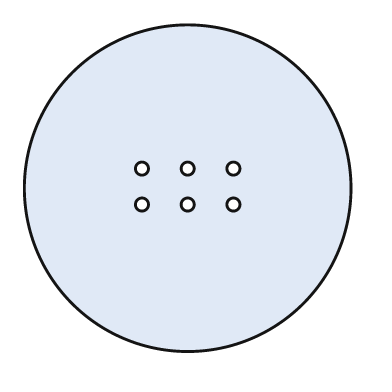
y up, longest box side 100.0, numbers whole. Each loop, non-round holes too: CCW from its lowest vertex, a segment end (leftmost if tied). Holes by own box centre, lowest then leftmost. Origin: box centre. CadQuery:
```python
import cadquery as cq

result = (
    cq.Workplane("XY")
    .moveTo(0.0, 0.0)
    .circle(50.0)
    .moveTo(-14.0, -5.0)
    .circle(2.0)
    .moveTo(0.0, -5.0)
    .circle(2.0)
    .moveTo(14.0, -5.0)
    .circle(2.0)
    .moveTo(-14.0, 6.0)
    .circle(2.0)
    .moveTo(0.0, 6.0)
    .circle(2.0)
    .moveTo(14.0, 6.0)
    .circle(2.0)
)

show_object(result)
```